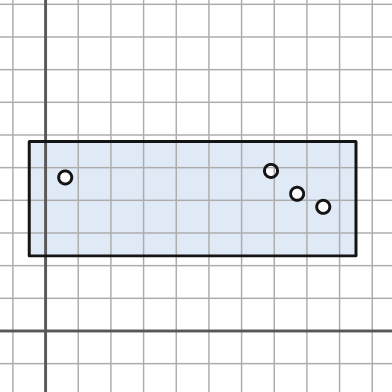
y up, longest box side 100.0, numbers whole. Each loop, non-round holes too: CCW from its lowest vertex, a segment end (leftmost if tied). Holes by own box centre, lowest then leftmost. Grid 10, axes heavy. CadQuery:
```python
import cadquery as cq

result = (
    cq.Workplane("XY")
    .moveTo(-5.0, 23.0)
    .lineTo(95.0, 23.0)
    .lineTo(95.0, 58.0)
    .lineTo(-5.0, 58.0)
    .close()
    .moveTo(85.0, 38.0)
    .circle(2.0)
    .moveTo(77.0, 42.0)
    .circle(2.0)
    .moveTo(6.0, 47.0)
    .circle(2.0)
    .moveTo(69.0, 49.0)
    .circle(2.0)
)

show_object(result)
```